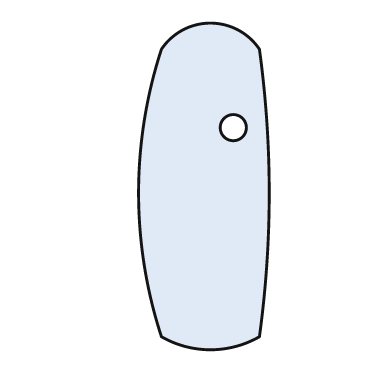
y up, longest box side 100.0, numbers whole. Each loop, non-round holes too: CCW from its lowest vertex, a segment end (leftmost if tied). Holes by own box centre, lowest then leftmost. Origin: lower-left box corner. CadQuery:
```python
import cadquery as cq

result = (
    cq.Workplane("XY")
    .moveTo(7.0, 4.0)
    .threePointArc((22.0, 0.0), (37.0, 4.0))
    .threePointArc((40.0, 48.0), (37.0, 92.0))
    .threePointArc((22.0, 100.0), (7.0, 92.0))
    .threePointArc((0.0, 48.0), (7.0, 4.0))
    .close()
    .moveTo(29.0, 68.0)
    .circle(4.0)
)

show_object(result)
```